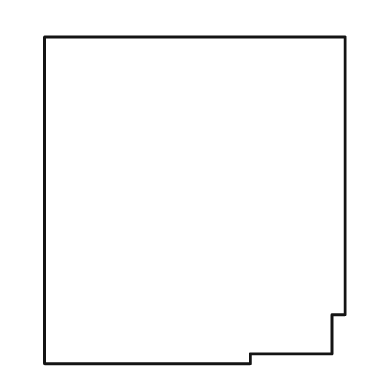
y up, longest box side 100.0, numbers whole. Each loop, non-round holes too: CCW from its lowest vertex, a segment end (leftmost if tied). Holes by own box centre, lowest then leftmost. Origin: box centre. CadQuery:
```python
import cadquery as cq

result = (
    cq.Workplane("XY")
    .moveTo(-46.0, -50.0)
    .lineTo(17.0, -50.0)
    .lineTo(17.0, -47.0)
    .lineTo(42.0, -47.0)
    .lineTo(42.0, -35.0)
    .lineTo(46.0, -35.0)
    .lineTo(46.0, 50.0)
    .lineTo(-46.0, 50.0)
    .close()
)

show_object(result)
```